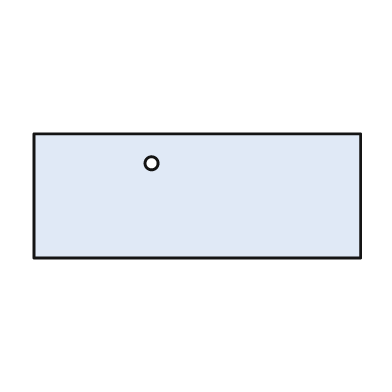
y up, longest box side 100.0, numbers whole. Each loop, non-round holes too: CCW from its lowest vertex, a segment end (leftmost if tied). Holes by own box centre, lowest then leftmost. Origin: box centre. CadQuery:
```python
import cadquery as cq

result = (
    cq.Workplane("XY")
    .moveTo(-50.0, -19.0)
    .lineTo(50.0, -19.0)
    .lineTo(50.0, 19.0)
    .lineTo(-50.0, 19.0)
    .close()
    .moveTo(-14.0, 10.0)
    .circle(2.0)
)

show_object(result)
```